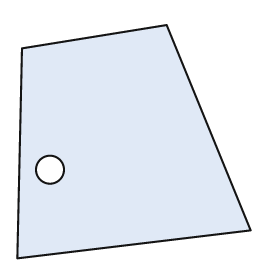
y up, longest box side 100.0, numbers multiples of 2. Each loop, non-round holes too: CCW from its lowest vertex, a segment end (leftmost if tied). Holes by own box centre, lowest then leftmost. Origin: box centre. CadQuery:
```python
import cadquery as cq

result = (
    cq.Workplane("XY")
    .moveTo(-50.0, -50.0)
    .lineTo(50.0, -38.0)
    .lineTo(14.0, 50.0)
    .lineTo(-48.0, 40.0)
    .close()
    .moveTo(-36.0, -12.0)
    .circle(6.0)
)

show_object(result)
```